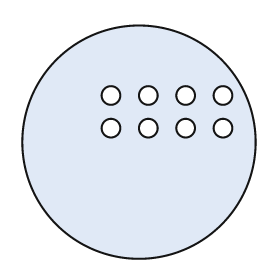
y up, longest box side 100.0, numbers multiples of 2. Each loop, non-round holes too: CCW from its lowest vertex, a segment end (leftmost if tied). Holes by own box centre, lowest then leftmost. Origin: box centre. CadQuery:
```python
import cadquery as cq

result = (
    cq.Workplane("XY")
    .moveTo(0.0, 0.0)
    .circle(50.0)
    .moveTo(-12.0, 6.0)
    .circle(4.0)
    .moveTo(4.0, 6.0)
    .circle(4.0)
    .moveTo(20.0, 6.0)
    .circle(4.0)
    .moveTo(36.0, 6.0)
    .circle(4.0)
    .moveTo(-12.0, 20.0)
    .circle(4.0)
    .moveTo(4.0, 20.0)
    .circle(4.0)
    .moveTo(20.0, 20.0)
    .circle(4.0)
    .moveTo(36.0, 20.0)
    .circle(4.0)
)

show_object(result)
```